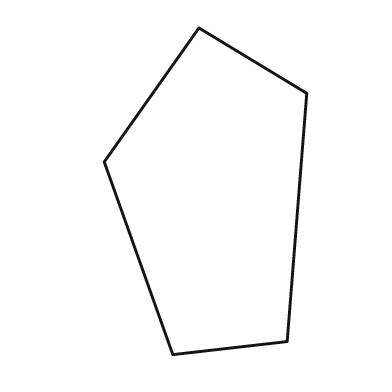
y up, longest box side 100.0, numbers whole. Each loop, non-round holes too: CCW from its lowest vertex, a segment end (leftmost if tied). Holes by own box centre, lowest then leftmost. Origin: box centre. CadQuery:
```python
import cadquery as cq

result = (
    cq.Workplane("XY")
    .moveTo(-10.0, -50.0)
    .lineTo(25.0, -46.0)
    .lineTo(31.0, 30.0)
    .lineTo(-2.0, 50.0)
    .lineTo(-31.0, 9.0)
    .close()
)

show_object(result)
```